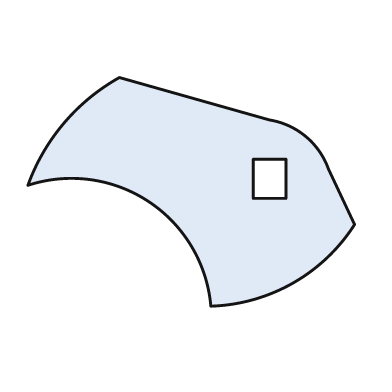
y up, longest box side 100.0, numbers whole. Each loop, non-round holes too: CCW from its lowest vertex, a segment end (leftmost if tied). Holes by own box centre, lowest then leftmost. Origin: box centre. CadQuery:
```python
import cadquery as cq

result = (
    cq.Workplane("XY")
    .moveTo(6.0, -35.0)
    .threePointArc((31.0, -28.0), (50.0, -10.0))
    .lineTo(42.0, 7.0)
    .threePointArc((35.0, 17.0), (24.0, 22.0))
    .lineTo(-22.0, 35.0)
    .threePointArc((-39.0, 21.0), (-50.0, 2.0))
    .threePointArc((-13.0, -3.0), (6.0, -35.0))
    .close()
    .moveTo(19.0, -2.0)
    .lineTo(29.0, -2.0)
    .lineTo(29.0, 10.0)
    .lineTo(19.0, 10.0)
    .close()
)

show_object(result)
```